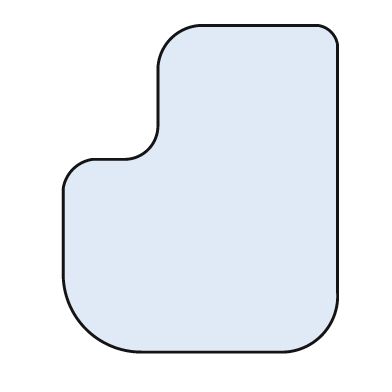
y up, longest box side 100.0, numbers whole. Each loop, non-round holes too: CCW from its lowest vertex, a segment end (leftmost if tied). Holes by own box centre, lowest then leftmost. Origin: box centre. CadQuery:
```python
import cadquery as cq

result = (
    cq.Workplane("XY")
    .moveTo(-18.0, -50.0)
    .lineTo(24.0, -50.0)
    .threePointArc((37.0, -45.0), (42.0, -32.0))
    .lineTo(42.0, 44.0)
    .threePointArc((40.0, 48.0), (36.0, 50.0))
    .lineTo(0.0, 50.0)
    .threePointArc((-9.0, 46.0), (-13.0, 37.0))
    .lineTo(-13.0, 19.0)
    .threePointArc((-16.0, 12.0), (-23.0, 9.0))
    .lineTo(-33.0, 9.0)
    .threePointArc((-39.0, 6.0), (-42.0, 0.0))
    .lineTo(-42.0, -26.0)
    .threePointArc((-35.0, -43.0), (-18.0, -50.0))
    .close()
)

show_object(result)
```